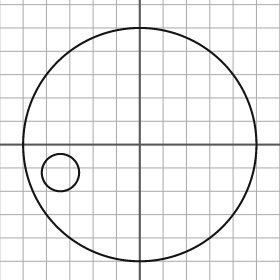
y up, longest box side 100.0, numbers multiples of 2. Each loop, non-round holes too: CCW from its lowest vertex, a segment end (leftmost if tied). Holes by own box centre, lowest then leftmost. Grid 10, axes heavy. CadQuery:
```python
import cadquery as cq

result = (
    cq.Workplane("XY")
    .moveTo(0.0, 0.0)
    .circle(50.0)
    .moveTo(-34.0, -12.0)
    .circle(8.0)
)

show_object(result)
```